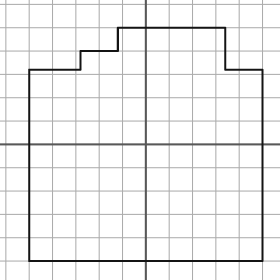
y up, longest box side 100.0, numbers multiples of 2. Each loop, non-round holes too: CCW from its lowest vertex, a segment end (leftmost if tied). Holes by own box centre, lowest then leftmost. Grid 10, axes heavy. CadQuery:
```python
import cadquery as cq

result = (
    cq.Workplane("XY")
    .moveTo(-50.0, -50.0)
    .lineTo(50.0, -50.0)
    .lineTo(50.0, 32.0)
    .lineTo(34.0, 32.0)
    .lineTo(34.0, 50.0)
    .lineTo(-12.0, 50.0)
    .lineTo(-12.0, 40.0)
    .lineTo(-28.0, 40.0)
    .lineTo(-28.0, 32.0)
    .lineTo(-50.0, 32.0)
    .close()
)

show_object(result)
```